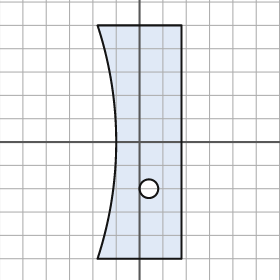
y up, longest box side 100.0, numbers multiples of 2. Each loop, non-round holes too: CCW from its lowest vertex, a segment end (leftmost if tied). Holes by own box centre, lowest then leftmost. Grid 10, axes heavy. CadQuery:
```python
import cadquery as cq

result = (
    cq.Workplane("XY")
    .moveTo(-18.0, -50.0)
    .lineTo(18.0, -50.0)
    .lineTo(18.0, 50.0)
    .lineTo(-18.0, 50.0)
    .threePointArc((-10.0, 0.0), (-18.0, -50.0))
    .close()
    .moveTo(4.0, -20.0)
    .circle(4.0)
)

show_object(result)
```